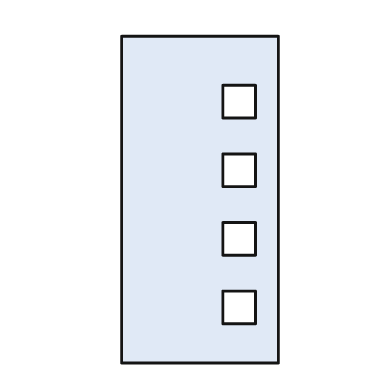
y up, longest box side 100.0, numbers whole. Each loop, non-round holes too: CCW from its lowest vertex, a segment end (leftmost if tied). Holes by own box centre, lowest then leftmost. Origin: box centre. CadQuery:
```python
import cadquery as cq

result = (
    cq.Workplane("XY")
    .moveTo(-24.0, -50.0)
    .lineTo(24.0, -50.0)
    .lineTo(24.0, 50.0)
    .lineTo(-24.0, 50.0)
    .close()
    .moveTo(7.0, -38.0)
    .lineTo(17.0, -38.0)
    .lineTo(17.0, -28.0)
    .lineTo(7.0, -28.0)
    .close()
    .moveTo(7.0, -17.0)
    .lineTo(17.0, -17.0)
    .lineTo(17.0, -7.0)
    .lineTo(7.0, -7.0)
    .close()
    .moveTo(7.0, 4.0)
    .lineTo(17.0, 4.0)
    .lineTo(17.0, 14.0)
    .lineTo(7.0, 14.0)
    .close()
    .moveTo(7.0, 25.0)
    .lineTo(17.0, 25.0)
    .lineTo(17.0, 35.0)
    .lineTo(7.0, 35.0)
    .close()
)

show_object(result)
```